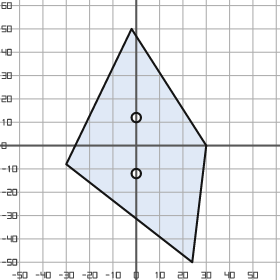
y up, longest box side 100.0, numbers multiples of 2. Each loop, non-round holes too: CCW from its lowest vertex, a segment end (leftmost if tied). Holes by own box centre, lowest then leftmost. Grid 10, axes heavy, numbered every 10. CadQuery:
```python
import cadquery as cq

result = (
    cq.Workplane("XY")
    .moveTo(24.0, -50.0)
    .lineTo(30.0, 0.0)
    .lineTo(-2.0, 50.0)
    .lineTo(-30.0, -8.0)
    .close()
    .moveTo(0.0, -12.0)
    .circle(2.0)
    .moveTo(0.0, 12.0)
    .circle(2.0)
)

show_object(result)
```